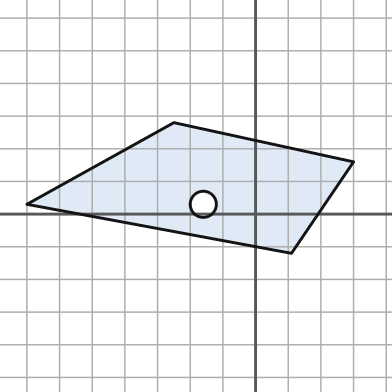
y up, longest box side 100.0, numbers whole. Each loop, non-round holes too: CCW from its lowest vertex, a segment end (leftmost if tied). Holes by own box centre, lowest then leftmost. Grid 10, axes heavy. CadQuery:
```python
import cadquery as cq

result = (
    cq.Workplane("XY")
    .moveTo(11.0, -12.0)
    .lineTo(30.0, 16.0)
    .lineTo(-25.0, 28.0)
    .lineTo(-70.0, 3.0)
    .close()
    .moveTo(-16.0, 3.0)
    .circle(4.0)
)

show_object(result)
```